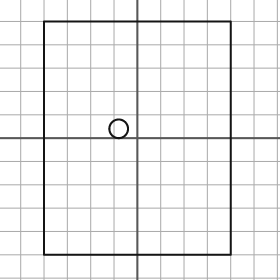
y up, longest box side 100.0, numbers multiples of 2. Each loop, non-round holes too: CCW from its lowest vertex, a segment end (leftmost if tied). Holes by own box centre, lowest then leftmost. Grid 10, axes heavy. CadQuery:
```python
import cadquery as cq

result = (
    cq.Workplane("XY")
    .moveTo(-40.0, -50.0)
    .lineTo(40.0, -50.0)
    .lineTo(40.0, 50.0)
    .lineTo(-40.0, 50.0)
    .close()
    .moveTo(-8.0, 4.0)
    .circle(4.0)
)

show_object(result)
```